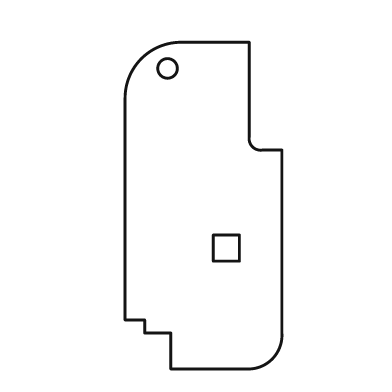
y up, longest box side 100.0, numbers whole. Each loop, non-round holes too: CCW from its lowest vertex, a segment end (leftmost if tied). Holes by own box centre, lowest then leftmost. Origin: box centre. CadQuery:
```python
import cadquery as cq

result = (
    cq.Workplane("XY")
    .moveTo(-10.0, -50.0)
    .lineTo(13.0, -50.0)
    .threePointArc((21.0, -47.0), (24.0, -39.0))
    .lineTo(24.0, 17.0)
    .lineTo(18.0, 17.0)
    .threePointArc((15.0, 18.0), (14.0, 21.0))
    .lineTo(14.0, 50.0)
    .lineTo(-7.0, 50.0)
    .threePointArc((-19.0, 45.0), (-24.0, 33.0))
    .lineTo(-24.0, -35.0)
    .lineTo(-18.0, -35.0)
    .lineTo(-18.0, -39.0)
    .lineTo(-10.0, -39.0)
    .close()
    .moveTo(3.0, -17.0)
    .lineTo(11.0, -17.0)
    .lineTo(11.0, -9.0)
    .lineTo(3.0, -9.0)
    .close()
    .moveTo(-11.0, 42.0)
    .circle(3.0)
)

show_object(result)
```